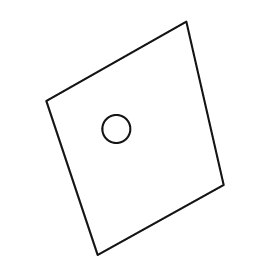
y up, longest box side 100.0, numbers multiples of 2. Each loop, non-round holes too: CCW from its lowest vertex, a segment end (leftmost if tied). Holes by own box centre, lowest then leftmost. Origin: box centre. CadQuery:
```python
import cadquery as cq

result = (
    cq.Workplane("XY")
    .moveTo(-16.0, -50.0)
    .lineTo(38.0, -20.0)
    .lineTo(22.0, 50.0)
    .lineTo(-38.0, 16.0)
    .close()
    .moveTo(-8.0, 4.0)
    .circle(6.0)
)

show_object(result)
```